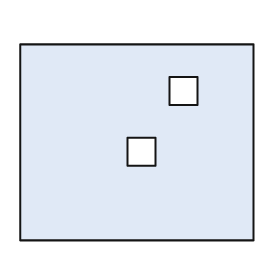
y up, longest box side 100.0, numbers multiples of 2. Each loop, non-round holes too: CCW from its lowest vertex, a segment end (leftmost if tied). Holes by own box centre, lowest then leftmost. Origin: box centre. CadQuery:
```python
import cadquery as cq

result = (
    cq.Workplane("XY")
    .moveTo(-50.0, -42.0)
    .lineTo(50.0, -42.0)
    .lineTo(50.0, 42.0)
    .lineTo(-50.0, 42.0)
    .close()
    .moveTo(-4.0, -10.0)
    .lineTo(8.0, -10.0)
    .lineTo(8.0, 2.0)
    .lineTo(-4.0, 2.0)
    .close()
    .moveTo(14.0, 16.0)
    .lineTo(26.0, 16.0)
    .lineTo(26.0, 28.0)
    .lineTo(14.0, 28.0)
    .close()
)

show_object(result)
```